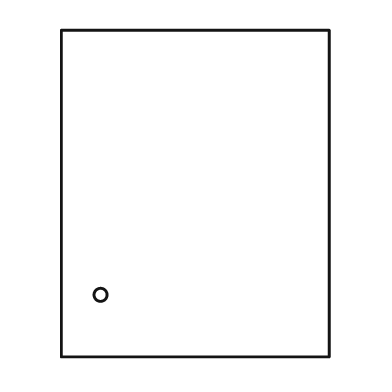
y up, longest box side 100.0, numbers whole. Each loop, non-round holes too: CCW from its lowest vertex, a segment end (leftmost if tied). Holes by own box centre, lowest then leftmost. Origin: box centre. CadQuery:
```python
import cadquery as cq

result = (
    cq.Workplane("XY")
    .moveTo(-41.0, -50.0)
    .lineTo(41.0, -50.0)
    .lineTo(41.0, 50.0)
    .lineTo(-41.0, 50.0)
    .close()
    .moveTo(-29.0, -31.0)
    .circle(2.0)
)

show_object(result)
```